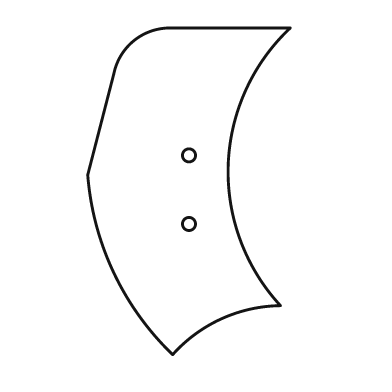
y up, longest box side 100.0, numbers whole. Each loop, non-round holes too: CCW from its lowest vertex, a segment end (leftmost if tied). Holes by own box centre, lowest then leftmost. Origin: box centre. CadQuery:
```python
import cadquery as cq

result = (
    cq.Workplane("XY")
    .moveTo(-5.0, -50.0)
    .threePointArc((10.0, -39.0), (28.0, -35.0))
    .threePointArc((12.0, 8.0), (31.0, 50.0))
    .lineTo(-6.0, 50.0)
    .threePointArc((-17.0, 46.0), (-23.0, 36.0))
    .lineTo(-31.0, 5.0)
    .threePointArc((-23.0, -25.0), (-5.0, -50.0))
    .close()
    .moveTo(0.0, -10.0)
    .circle(2.0)
    .moveTo(0.0, 11.0)
    .circle(2.0)
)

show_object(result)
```